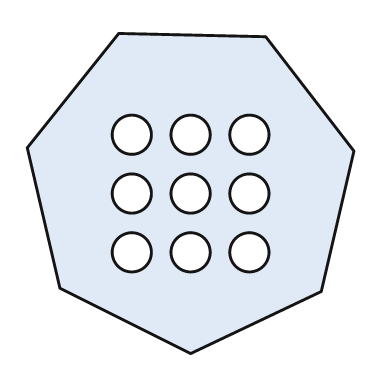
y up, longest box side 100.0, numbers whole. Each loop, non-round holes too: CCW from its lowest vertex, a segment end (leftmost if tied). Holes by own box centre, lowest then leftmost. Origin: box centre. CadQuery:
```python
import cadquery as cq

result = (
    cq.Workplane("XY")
    .moveTo(0.0, -49.0)
    .lineTo(40.0, -30.0)
    .lineTo(50.0, 13.0)
    .lineTo(23.0, 48.0)
    .lineTo(-22.0, 49.0)
    .lineTo(-50.0, 14.0)
    .lineTo(-40.0, -29.0)
    .close()
    .moveTo(-18.0, -18.0)
    .circle(6.0)
    .moveTo(0.0, -18.0)
    .circle(6.0)
    .moveTo(18.0, -18.0)
    .circle(6.0)
    .moveTo(-18.0, 0.0)
    .circle(6.0)
    .moveTo(0.0, 0.0)
    .circle(6.0)
    .moveTo(18.0, 0.0)
    .circle(6.0)
    .moveTo(-18.0, 18.0)
    .circle(6.0)
    .moveTo(0.0, 18.0)
    .circle(6.0)
    .moveTo(18.0, 18.0)
    .circle(6.0)
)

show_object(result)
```